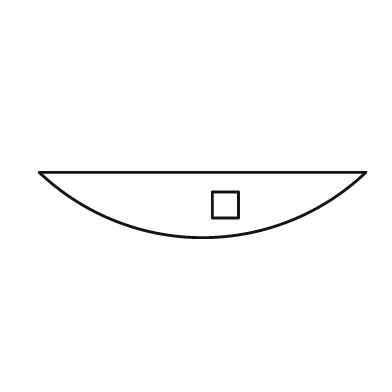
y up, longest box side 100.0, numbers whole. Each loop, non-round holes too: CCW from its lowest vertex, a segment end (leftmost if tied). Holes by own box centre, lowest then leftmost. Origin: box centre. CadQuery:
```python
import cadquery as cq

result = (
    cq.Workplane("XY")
    .moveTo(-50.0, 10.0)
    .threePointArc((0.0, -10.0), (50.0, 10.0))
    .close()
    .moveTo(3.0, -4.0)
    .lineTo(11.0, -4.0)
    .lineTo(11.0, 4.0)
    .lineTo(3.0, 4.0)
    .close()
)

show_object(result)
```